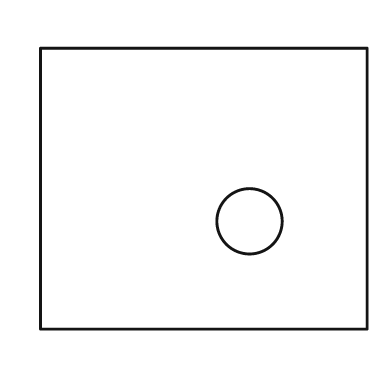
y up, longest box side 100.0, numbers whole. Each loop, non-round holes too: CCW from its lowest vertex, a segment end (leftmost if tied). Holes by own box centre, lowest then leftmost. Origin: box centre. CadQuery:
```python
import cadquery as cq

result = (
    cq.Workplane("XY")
    .moveTo(-50.0, -43.0)
    .lineTo(50.0, -43.0)
    .lineTo(50.0, 43.0)
    .lineTo(-50.0, 43.0)
    .close()
    .moveTo(14.0, -10.0)
    .circle(10.0)
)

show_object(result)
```